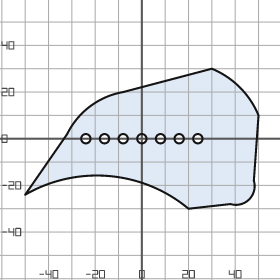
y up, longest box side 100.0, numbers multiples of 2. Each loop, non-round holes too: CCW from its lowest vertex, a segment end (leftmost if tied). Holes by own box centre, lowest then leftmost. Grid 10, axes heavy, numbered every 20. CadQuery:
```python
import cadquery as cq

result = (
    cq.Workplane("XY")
    .moveTo(20.0, -30.0)
    .lineTo(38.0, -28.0)
    .threePointArc((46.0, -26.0), (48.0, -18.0))
    .lineTo(50.0, 10.0)
    .threePointArc((42.0, 22.0), (30.0, 30.0))
    .lineTo(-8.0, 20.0)
    .threePointArc((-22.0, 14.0), (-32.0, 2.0))
    .lineTo(-50.0, -24.0)
    .threePointArc((-14.0, -16.0), (20.0, -30.0))
    .close()
    .moveTo(-24.0, 0.0)
    .circle(2.0)
    .moveTo(-16.0, 0.0)
    .circle(2.0)
    .moveTo(-8.0, 0.0)
    .circle(2.0)
    .moveTo(0.0, 0.0)
    .circle(2.0)
    .moveTo(8.0, 0.0)
    .circle(2.0)
    .moveTo(16.0, 0.0)
    .circle(2.0)
    .moveTo(24.0, 0.0)
    .circle(2.0)
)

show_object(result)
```